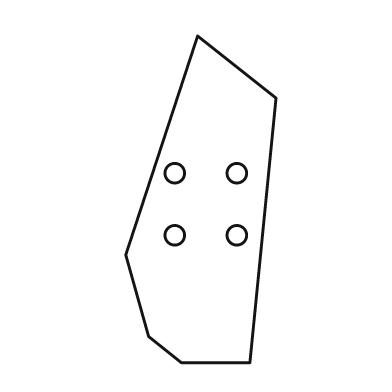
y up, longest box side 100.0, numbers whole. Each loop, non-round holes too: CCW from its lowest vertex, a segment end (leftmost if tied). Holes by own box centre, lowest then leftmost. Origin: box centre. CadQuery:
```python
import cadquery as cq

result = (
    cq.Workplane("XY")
    .moveTo(-6.0, -50.0)
    .lineTo(15.0, -50.0)
    .lineTo(23.0, 31.0)
    .lineTo(-1.0, 50.0)
    .lineTo(-23.0, -17.0)
    .lineTo(-16.0, -42.0)
    .close()
    .moveTo(-8.0, -11.0)
    .circle(3.0)
    .moveTo(11.0, -11.0)
    .circle(3.0)
    .moveTo(-8.0, 8.0)
    .circle(3.0)
    .moveTo(11.0, 8.0)
    .circle(3.0)
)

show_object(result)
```